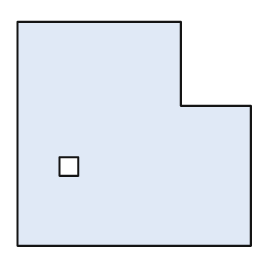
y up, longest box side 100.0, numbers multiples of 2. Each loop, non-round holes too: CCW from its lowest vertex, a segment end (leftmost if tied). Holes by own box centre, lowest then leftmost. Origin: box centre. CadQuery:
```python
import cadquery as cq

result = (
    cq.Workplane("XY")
    .moveTo(-50.0, -48.0)
    .lineTo(50.0, -48.0)
    .lineTo(50.0, 12.0)
    .lineTo(20.0, 12.0)
    .lineTo(20.0, 48.0)
    .lineTo(-50.0, 48.0)
    .close()
    .moveTo(-32.0, -18.0)
    .lineTo(-24.0, -18.0)
    .lineTo(-24.0, -10.0)
    .lineTo(-32.0, -10.0)
    .close()
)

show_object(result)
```